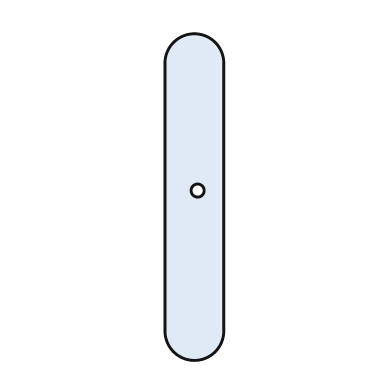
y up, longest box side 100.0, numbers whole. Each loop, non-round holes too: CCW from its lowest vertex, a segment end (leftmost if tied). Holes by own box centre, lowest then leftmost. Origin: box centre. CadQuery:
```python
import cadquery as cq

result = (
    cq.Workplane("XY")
    .moveTo(-9.0, -41.0)
    .threePointArc((0.0, -50.0), (9.0, -41.0))
    .lineTo(9.0, 41.0)
    .threePointArc((0.0, 50.0), (-9.0, 41.0))
    .close()
    .moveTo(1.0, 2.0)
    .circle(2.0)
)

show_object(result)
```